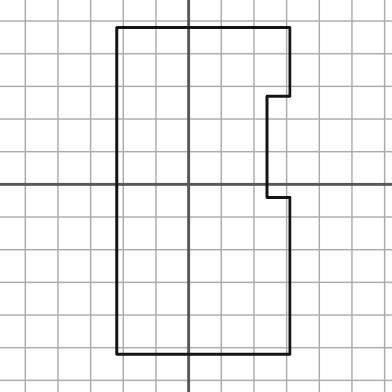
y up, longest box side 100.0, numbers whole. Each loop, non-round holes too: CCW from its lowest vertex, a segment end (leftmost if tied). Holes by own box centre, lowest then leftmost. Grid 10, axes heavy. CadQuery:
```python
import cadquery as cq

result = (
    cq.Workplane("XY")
    .moveTo(-22.0, -52.0)
    .lineTo(31.0, -52.0)
    .lineTo(31.0, -4.0)
    .lineTo(24.0, -4.0)
    .lineTo(24.0, 27.0)
    .lineTo(31.0, 27.0)
    .lineTo(31.0, 48.0)
    .lineTo(-22.0, 48.0)
    .close()
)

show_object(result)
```